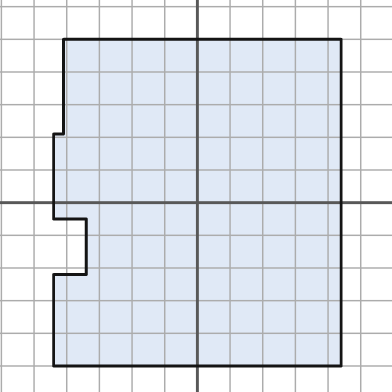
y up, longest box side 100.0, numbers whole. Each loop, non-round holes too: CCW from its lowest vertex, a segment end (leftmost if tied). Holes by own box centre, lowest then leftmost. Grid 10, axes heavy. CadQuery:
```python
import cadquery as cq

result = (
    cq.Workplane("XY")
    .moveTo(-44.0, -50.0)
    .lineTo(44.0, -50.0)
    .lineTo(44.0, 50.0)
    .lineTo(-41.0, 50.0)
    .lineTo(-41.0, 21.0)
    .lineTo(-44.0, 21.0)
    .lineTo(-44.0, -5.0)
    .lineTo(-34.0, -5.0)
    .lineTo(-34.0, -22.0)
    .lineTo(-44.0, -22.0)
    .close()
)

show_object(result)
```